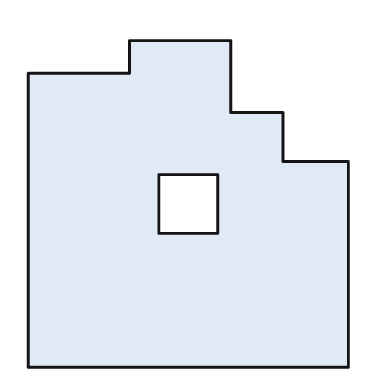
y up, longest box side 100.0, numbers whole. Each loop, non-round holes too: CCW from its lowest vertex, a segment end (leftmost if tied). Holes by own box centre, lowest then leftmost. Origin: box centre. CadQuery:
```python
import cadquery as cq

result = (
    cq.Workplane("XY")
    .moveTo(-49.0, -50.0)
    .lineTo(49.0, -50.0)
    .lineTo(49.0, 13.0)
    .lineTo(29.0, 13.0)
    .lineTo(29.0, 28.0)
    .lineTo(13.0, 28.0)
    .lineTo(13.0, 50.0)
    .lineTo(-18.0, 50.0)
    .lineTo(-18.0, 40.0)
    .lineTo(-49.0, 40.0)
    .close()
    .moveTo(-9.0, -9.0)
    .lineTo(9.0, -9.0)
    .lineTo(9.0, 9.0)
    .lineTo(-9.0, 9.0)
    .close()
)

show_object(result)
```